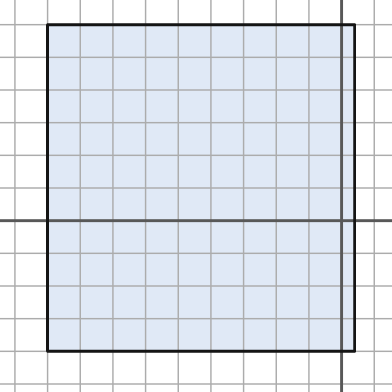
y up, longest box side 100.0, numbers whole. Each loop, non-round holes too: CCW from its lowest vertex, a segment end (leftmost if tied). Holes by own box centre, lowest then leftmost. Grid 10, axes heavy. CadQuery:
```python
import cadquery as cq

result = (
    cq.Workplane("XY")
    .moveTo(-90.0, -40.0)
    .lineTo(4.0, -40.0)
    .lineTo(4.0, 60.0)
    .lineTo(-90.0, 60.0)
    .close()
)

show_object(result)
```